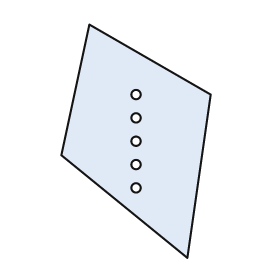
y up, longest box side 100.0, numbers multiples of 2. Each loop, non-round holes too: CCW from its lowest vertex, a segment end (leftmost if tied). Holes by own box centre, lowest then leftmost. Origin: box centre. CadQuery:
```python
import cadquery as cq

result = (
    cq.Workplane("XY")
    .moveTo(22.0, -50.0)
    .lineTo(32.0, 20.0)
    .lineTo(-20.0, 50.0)
    .lineTo(-32.0, -6.0)
    .close()
    .moveTo(0.0, -20.0)
    .circle(2.0)
    .moveTo(0.0, -10.0)
    .circle(2.0)
    .moveTo(0.0, 0.0)
    .circle(2.0)
    .moveTo(0.0, 10.0)
    .circle(2.0)
    .moveTo(0.0, 20.0)
    .circle(2.0)
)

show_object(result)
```